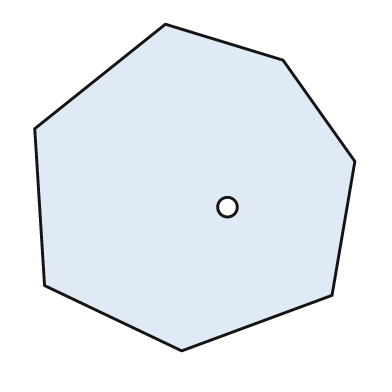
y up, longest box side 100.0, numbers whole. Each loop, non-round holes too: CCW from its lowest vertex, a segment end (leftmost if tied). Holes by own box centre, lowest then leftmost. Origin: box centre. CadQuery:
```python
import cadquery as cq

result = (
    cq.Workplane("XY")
    .moveTo(-4.0, -50.0)
    .lineTo(42.0, -33.0)
    .lineTo(49.0, 8.0)
    .lineTo(27.0, 39.0)
    .lineTo(-9.0, 50.0)
    .lineTo(-49.0, 18.0)
    .lineTo(-46.0, -30.0)
    .close()
    .moveTo(10.0, -6.0)
    .circle(3.0)
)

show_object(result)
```